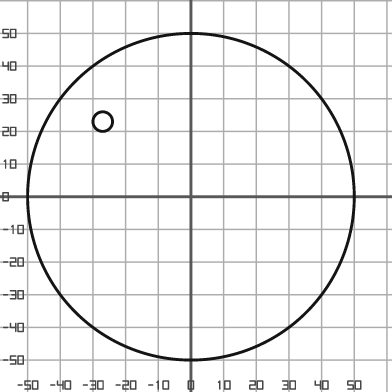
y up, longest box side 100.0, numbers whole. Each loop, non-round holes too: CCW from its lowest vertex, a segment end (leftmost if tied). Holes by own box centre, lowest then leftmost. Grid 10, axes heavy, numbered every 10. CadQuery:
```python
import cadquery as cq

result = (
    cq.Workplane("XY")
    .moveTo(0.0, 0.0)
    .circle(50.0)
    .moveTo(-27.0, 23.0)
    .circle(3.0)
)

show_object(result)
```